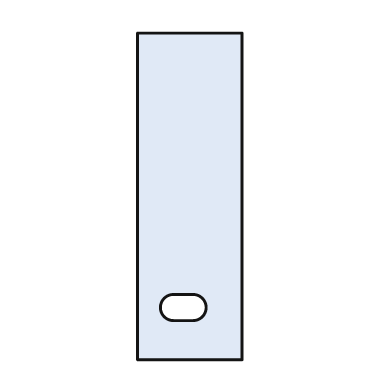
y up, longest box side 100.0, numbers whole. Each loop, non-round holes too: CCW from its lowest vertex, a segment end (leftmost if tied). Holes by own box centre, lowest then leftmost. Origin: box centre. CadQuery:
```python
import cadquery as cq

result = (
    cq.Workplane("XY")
    .moveTo(-16.0, -50.0)
    .lineTo(16.0, -50.0)
    .lineTo(16.0, 50.0)
    .lineTo(-16.0, 50.0)
    .close()
    .moveTo(-5.0, -38.0)
    .lineTo(1.0, -38.0)
    .threePointArc((5.0, -34.0), (1.0, -30.0))
    .lineTo(-5.0, -30.0)
    .threePointArc((-9.0, -34.0), (-5.0, -38.0))
    .close()
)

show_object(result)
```